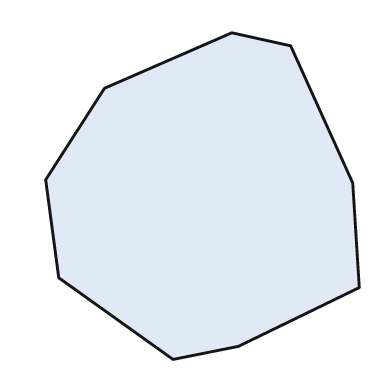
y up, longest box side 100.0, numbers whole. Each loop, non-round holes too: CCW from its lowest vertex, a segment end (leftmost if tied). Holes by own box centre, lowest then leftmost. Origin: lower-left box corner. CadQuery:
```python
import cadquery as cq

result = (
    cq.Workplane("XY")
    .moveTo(39.0, 0.0)
    .lineTo(59.0, 4.0)
    .lineTo(96.0, 22.0)
    .lineTo(94.0, 54.0)
    .lineTo(75.0, 96.0)
    .lineTo(57.0, 100.0)
    .lineTo(18.0, 83.0)
    .lineTo(0.0, 55.0)
    .lineTo(4.0, 25.0)
    .close()
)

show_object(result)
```